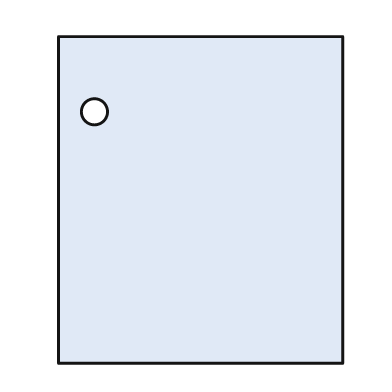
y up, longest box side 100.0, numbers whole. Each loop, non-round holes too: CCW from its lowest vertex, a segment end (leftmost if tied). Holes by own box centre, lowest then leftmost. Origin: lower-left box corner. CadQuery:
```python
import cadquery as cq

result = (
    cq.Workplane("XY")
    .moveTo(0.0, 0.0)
    .lineTo(87.0, 0.0)
    .lineTo(87.0, 100.0)
    .lineTo(0.0, 100.0)
    .close()
    .moveTo(11.0, 77.0)
    .circle(4.0)
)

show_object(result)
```